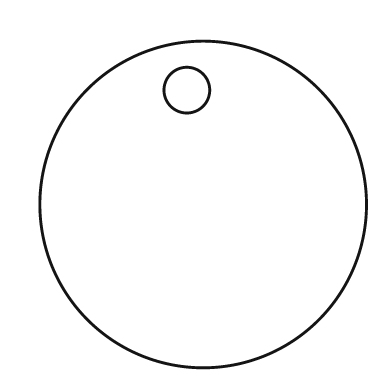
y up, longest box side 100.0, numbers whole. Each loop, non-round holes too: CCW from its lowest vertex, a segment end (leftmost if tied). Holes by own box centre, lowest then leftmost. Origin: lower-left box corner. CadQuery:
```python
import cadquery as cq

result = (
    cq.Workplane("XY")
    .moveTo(50.0, 50.0)
    .circle(50.0)
    .moveTo(45.0, 85.0)
    .circle(7.0)
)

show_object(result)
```